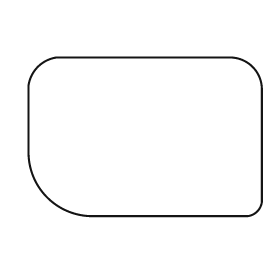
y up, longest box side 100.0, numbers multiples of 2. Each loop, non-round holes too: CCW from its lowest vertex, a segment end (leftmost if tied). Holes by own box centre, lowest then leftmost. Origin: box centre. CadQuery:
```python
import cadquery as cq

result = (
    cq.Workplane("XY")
    .moveTo(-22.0, -34.0)
    .lineTo(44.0, -34.0)
    .threePointArc((48.0, -32.0), (50.0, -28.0))
    .lineTo(50.0, 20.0)
    .threePointArc((46.0, 30.0), (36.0, 34.0))
    .lineTo(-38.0, 34.0)
    .threePointArc((-46.0, 30.0), (-50.0, 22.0))
    .lineTo(-50.0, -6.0)
    .threePointArc((-42.0, -26.0), (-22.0, -34.0))
    .close()
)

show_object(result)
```